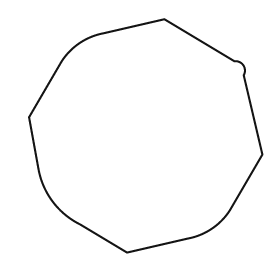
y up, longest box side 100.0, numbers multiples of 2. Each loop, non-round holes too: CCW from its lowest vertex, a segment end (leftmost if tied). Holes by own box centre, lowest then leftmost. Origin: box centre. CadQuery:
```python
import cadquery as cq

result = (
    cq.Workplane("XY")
    .moveTo(-8.0, -50.0)
    .lineTo(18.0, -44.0)
    .threePointArc((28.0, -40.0), (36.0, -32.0))
    .lineTo(50.0, -8.0)
    .lineTo(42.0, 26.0)
    .threePointArc((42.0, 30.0), (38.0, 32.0))
    .lineTo(8.0, 50.0)
    .lineTo(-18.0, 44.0)
    .threePointArc((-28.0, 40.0), (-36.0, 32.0))
    .lineTo(-50.0, 8.0)
    .lineTo(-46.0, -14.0)
    .threePointArc((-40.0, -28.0), (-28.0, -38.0))
    .close()
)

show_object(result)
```